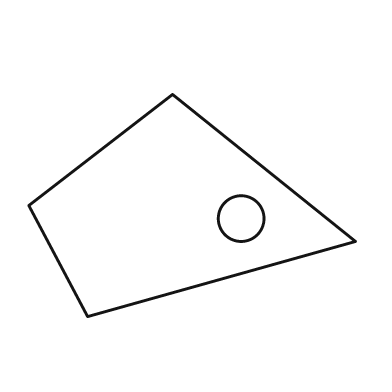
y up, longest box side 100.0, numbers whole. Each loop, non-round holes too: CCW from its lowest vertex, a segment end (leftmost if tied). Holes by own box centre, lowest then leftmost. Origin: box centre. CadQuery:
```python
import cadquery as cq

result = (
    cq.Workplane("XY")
    .moveTo(-32.0, -34.0)
    .lineTo(50.0, -11.0)
    .lineTo(-6.0, 34.0)
    .lineTo(-50.0, 0.0)
    .close()
    .moveTo(15.0, -4.0)
    .circle(7.0)
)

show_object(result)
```